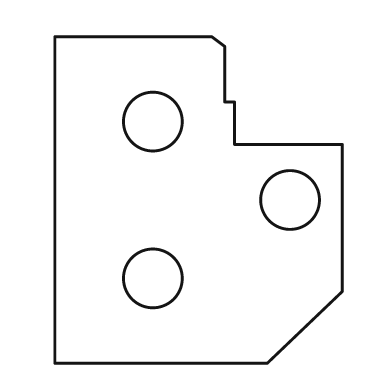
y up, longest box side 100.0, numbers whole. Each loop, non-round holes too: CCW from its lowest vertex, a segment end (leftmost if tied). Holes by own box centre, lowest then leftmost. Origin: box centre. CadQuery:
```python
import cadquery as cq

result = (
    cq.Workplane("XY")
    .moveTo(-44.0, -50.0)
    .lineTo(21.0, -50.0)
    .lineTo(44.0, -28.0)
    .lineTo(44.0, 17.0)
    .lineTo(11.0, 17.0)
    .lineTo(11.0, 30.0)
    .lineTo(8.0, 30.0)
    .lineTo(8.0, 47.0)
    .lineTo(4.0, 50.0)
    .lineTo(-44.0, 50.0)
    .close()
    .moveTo(-14.0, -24.0)
    .circle(9.0)
    .moveTo(28.0, 0.0)
    .circle(9.0)
    .moveTo(-14.0, 24.0)
    .circle(9.0)
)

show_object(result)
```